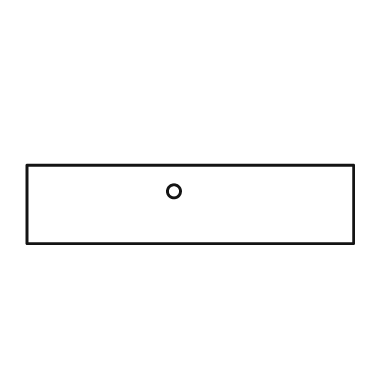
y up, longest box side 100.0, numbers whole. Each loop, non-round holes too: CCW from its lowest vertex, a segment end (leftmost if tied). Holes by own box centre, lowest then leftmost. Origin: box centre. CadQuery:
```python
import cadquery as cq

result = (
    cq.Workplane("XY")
    .moveTo(-50.0, -12.0)
    .lineTo(50.0, -12.0)
    .lineTo(50.0, 12.0)
    .lineTo(-50.0, 12.0)
    .close()
    .moveTo(-5.0, 4.0)
    .circle(2.0)
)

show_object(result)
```